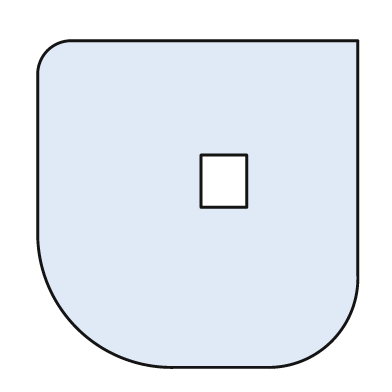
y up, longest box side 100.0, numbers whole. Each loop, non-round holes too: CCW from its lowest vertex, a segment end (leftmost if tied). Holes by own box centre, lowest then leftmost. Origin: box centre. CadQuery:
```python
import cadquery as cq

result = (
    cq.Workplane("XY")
    .moveTo(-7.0, -50.0)
    .lineTo(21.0, -50.0)
    .threePointArc((41.0, -42.0), (49.0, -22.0))
    .lineTo(49.0, 50.0)
    .lineTo(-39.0, 50.0)
    .threePointArc((-46.0, 47.0), (-49.0, 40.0))
    .lineTo(-49.0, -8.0)
    .threePointArc((-37.0, -38.0), (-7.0, -50.0))
    .close()
    .moveTo(1.0, -1.0)
    .lineTo(15.0, -1.0)
    .lineTo(15.0, 15.0)
    .lineTo(1.0, 15.0)
    .close()
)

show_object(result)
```